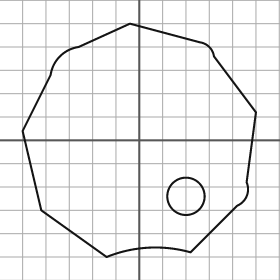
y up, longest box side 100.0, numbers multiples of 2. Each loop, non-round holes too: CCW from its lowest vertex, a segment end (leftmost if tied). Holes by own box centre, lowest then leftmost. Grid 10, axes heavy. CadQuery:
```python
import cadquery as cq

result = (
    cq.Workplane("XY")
    .moveTo(-14.0, -50.0)
    .threePointArc((4.0, -46.0), (22.0, -48.0))
    .lineTo(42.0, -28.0)
    .threePointArc((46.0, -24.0), (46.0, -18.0))
    .lineTo(50.0, 12.0)
    .lineTo(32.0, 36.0)
    .threePointArc((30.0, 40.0), (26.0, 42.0))
    .lineTo(-4.0, 50.0)
    .lineTo(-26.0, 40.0)
    .threePointArc((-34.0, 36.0), (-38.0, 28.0))
    .lineTo(-50.0, 4.0)
    .lineTo(-42.0, -30.0)
    .close()
    .moveTo(20.0, -24.0)
    .circle(8.0)
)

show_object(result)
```